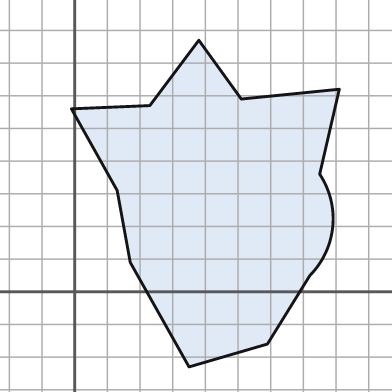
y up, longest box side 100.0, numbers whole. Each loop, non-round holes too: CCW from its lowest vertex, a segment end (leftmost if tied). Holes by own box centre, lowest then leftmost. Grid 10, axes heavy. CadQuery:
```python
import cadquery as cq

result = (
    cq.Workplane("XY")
    .moveTo(35.0, -23.0)
    .lineTo(59.0, -16.0)
    .lineTo(72.0, 5.0)
    .threePointArc((79.0, 20.0), (75.0, 36.0))
    .lineTo(81.0, 62.0)
    .lineTo(51.0, 59.0)
    .lineTo(38.0, 77.0)
    .lineTo(23.0, 57.0)
    .lineTo(-1.0, 56.0)
    .lineTo(13.0, 31.0)
    .lineTo(17.0, 9.0)
    .close()
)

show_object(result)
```